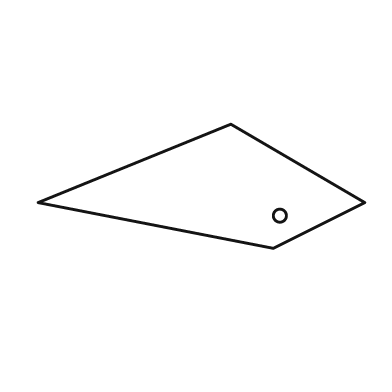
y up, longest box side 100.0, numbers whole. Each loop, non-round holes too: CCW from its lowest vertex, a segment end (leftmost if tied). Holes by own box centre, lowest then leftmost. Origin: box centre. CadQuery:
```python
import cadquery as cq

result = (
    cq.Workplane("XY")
    .moveTo(22.0, -19.0)
    .lineTo(50.0, -5.0)
    .lineTo(9.0, 19.0)
    .lineTo(-50.0, -5.0)
    .close()
    .moveTo(24.0, -9.0)
    .circle(2.0)
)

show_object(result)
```